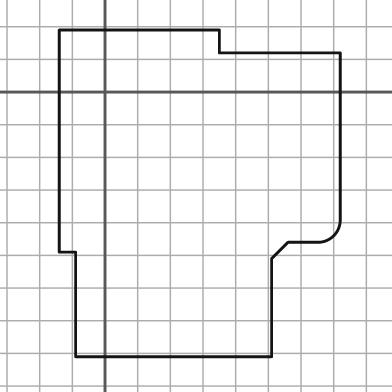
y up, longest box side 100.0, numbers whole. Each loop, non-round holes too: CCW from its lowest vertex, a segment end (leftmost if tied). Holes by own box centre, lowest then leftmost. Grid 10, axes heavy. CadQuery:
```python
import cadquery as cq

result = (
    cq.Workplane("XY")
    .moveTo(-9.0, -81.0)
    .lineTo(51.0, -81.0)
    .lineTo(51.0, -51.0)
    .lineTo(56.0, -46.0)
    .lineTo(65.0, -46.0)
    .threePointArc((70.0, -44.0), (72.0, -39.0))
    .lineTo(72.0, 12.0)
    .lineTo(35.0, 12.0)
    .lineTo(35.0, 19.0)
    .lineTo(-14.0, 19.0)
    .lineTo(-14.0, -49.0)
    .lineTo(-9.0, -49.0)
    .close()
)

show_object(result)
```